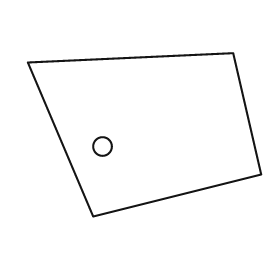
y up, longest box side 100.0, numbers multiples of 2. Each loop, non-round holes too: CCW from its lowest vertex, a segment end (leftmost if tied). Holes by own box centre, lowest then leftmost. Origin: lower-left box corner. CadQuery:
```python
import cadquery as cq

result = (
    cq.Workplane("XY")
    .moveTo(28.0, 0.0)
    .lineTo(100.0, 18.0)
    .lineTo(88.0, 70.0)
    .lineTo(0.0, 66.0)
    .close()
    .moveTo(32.0, 30.0)
    .circle(4.0)
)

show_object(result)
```